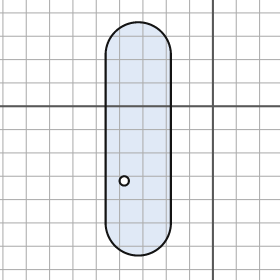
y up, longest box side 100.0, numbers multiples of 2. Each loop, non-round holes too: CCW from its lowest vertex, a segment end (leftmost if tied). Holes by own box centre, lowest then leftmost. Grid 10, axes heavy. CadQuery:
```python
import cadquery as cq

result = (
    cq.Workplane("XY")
    .moveTo(-46.0, -50.0)
    .threePointArc((-32.0, -64.0), (-18.0, -50.0))
    .lineTo(-18.0, 22.0)
    .threePointArc((-32.0, 36.0), (-46.0, 22.0))
    .close()
    .moveTo(-38.0, -32.0)
    .circle(2.0)
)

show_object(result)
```